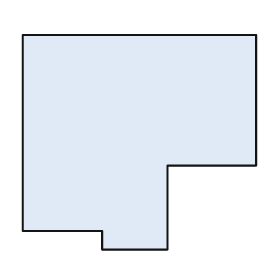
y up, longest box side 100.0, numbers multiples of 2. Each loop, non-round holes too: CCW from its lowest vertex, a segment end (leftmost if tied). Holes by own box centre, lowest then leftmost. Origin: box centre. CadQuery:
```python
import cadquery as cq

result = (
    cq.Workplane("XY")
    .moveTo(-16.0, -46.0)
    .lineTo(12.0, -46.0)
    .lineTo(12.0, -10.0)
    .lineTo(50.0, -10.0)
    .lineTo(50.0, 46.0)
    .lineTo(-50.0, 46.0)
    .lineTo(-50.0, -38.0)
    .lineTo(-16.0, -38.0)
    .close()
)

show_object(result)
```